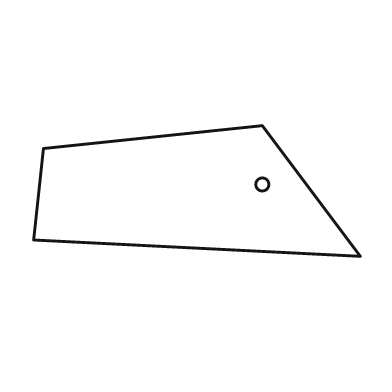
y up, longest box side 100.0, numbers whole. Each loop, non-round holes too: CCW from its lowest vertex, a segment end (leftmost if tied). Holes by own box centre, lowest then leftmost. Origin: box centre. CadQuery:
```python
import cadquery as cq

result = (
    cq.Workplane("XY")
    .moveTo(50.0, -20.0)
    .lineTo(20.0, 20.0)
    .lineTo(-47.0, 13.0)
    .lineTo(-50.0, -15.0)
    .close()
    .moveTo(20.0, 2.0)
    .circle(2.0)
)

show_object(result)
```